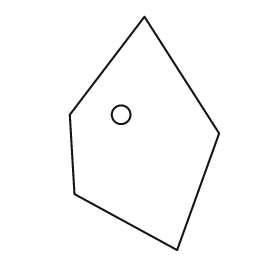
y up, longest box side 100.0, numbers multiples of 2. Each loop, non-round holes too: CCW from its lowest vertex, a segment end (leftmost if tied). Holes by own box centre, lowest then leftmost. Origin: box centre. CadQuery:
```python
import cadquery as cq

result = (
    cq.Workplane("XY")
    .moveTo(14.0, -50.0)
    .lineTo(32.0, 0.0)
    .lineTo(0.0, 50.0)
    .lineTo(-32.0, 8.0)
    .lineTo(-30.0, -26.0)
    .close()
    .moveTo(-10.0, 8.0)
    .circle(4.0)
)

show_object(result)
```